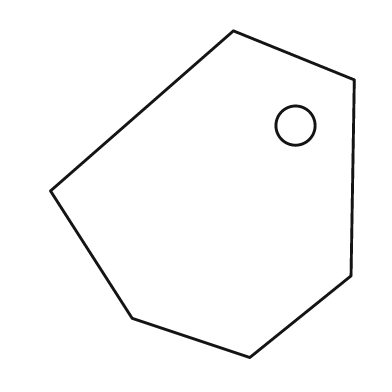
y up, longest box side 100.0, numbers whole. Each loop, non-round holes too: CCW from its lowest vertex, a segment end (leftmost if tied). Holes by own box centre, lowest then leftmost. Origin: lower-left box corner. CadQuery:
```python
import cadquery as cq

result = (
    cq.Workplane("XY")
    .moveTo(61.0, 0.0)
    .lineTo(92.0, 25.0)
    .lineTo(93.0, 85.0)
    .lineTo(56.0, 100.0)
    .lineTo(0.0, 51.0)
    .lineTo(25.0, 12.0)
    .close()
    .moveTo(75.0, 71.0)
    .circle(6.0)
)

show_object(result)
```